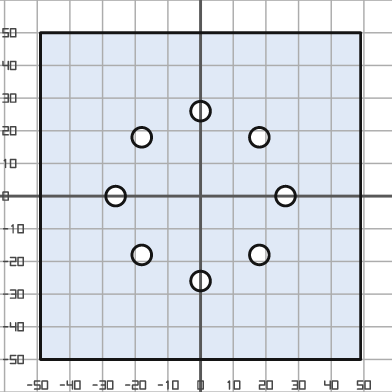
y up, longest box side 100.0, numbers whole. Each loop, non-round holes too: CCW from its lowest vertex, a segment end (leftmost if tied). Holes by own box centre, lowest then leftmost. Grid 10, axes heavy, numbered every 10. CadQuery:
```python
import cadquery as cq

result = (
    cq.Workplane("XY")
    .moveTo(-49.0, -50.0)
    .lineTo(49.0, -50.0)
    .lineTo(49.0, 50.0)
    .lineTo(-49.0, 50.0)
    .close()
    .moveTo(0.0, -26.0)
    .circle(3.0)
    .moveTo(-18.0, -18.0)
    .circle(3.0)
    .moveTo(18.0, -18.0)
    .circle(3.0)
    .moveTo(-26.0, 0.0)
    .circle(3.0)
    .moveTo(26.0, 0.0)
    .circle(3.0)
    .moveTo(-18.0, 18.0)
    .circle(3.0)
    .moveTo(18.0, 18.0)
    .circle(3.0)
    .moveTo(0.0, 26.0)
    .circle(3.0)
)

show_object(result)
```